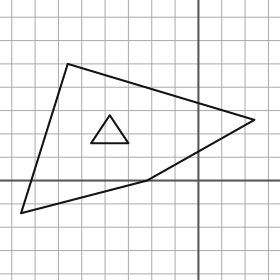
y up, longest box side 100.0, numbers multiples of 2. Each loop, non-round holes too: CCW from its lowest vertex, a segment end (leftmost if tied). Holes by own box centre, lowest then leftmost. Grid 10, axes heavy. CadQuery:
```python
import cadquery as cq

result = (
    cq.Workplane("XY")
    .moveTo(-76.0, -14.0)
    .lineTo(-22.0, 0.0)
    .lineTo(24.0, 26.0)
    .lineTo(-56.0, 50.0)
    .close()
    .moveTo(-46.0, 16.0)
    .lineTo(-30.0, 16.0)
    .lineTo(-38.0, 28.0)
    .close()
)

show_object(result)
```